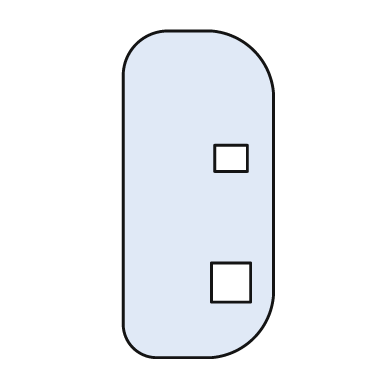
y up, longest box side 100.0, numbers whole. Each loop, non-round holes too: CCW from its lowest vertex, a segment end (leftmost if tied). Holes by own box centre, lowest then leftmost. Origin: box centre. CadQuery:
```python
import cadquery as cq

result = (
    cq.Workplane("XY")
    .moveTo(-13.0, -50.0)
    .lineTo(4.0, -50.0)
    .threePointArc((17.0, -44.0), (23.0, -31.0))
    .lineTo(23.0, 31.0)
    .threePointArc((17.0, 44.0), (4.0, 50.0))
    .lineTo(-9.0, 50.0)
    .threePointArc((-19.0, 46.0), (-23.0, 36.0))
    .lineTo(-23.0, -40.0)
    .threePointArc((-20.0, -47.0), (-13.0, -50.0))
    .close()
    .moveTo(4.0, -33.0)
    .lineTo(16.0, -33.0)
    .lineTo(16.0, -21.0)
    .lineTo(4.0, -21.0)
    .close()
    .moveTo(5.0, 7.0)
    .lineTo(15.0, 7.0)
    .lineTo(15.0, 15.0)
    .lineTo(5.0, 15.0)
    .close()
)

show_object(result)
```